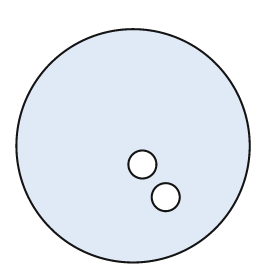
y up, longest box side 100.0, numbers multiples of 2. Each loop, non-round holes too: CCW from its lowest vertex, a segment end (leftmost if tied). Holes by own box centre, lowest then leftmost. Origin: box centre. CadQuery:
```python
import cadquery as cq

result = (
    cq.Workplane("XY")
    .moveTo(0.0, 0.0)
    .circle(50.0)
    .moveTo(14.0, -22.0)
    .circle(6.0)
    .moveTo(4.0, -8.0)
    .circle(6.0)
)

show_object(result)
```